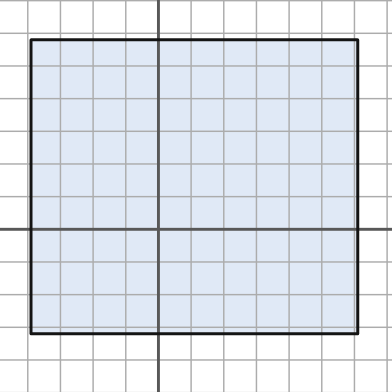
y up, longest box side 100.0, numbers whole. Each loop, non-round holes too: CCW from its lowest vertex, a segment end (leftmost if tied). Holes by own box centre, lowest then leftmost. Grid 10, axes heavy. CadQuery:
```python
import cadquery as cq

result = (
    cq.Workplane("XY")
    .moveTo(-39.0, -32.0)
    .lineTo(61.0, -32.0)
    .lineTo(61.0, 58.0)
    .lineTo(-39.0, 58.0)
    .close()
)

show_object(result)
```